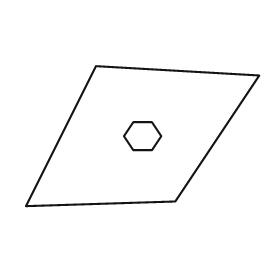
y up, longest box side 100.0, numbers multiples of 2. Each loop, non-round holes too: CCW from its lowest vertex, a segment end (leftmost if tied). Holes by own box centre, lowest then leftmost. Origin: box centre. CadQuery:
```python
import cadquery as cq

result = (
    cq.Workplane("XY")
    .moveTo(-50.0, -30.0)
    .lineTo(14.0, -28.0)
    .lineTo(50.0, 26.0)
    .lineTo(-20.0, 30.0)
    .close()
    .moveTo(-4.0, -6.0)
    .lineTo(4.0, -6.0)
    .lineTo(8.0, 0.0)
    .lineTo(4.0, 6.0)
    .lineTo(-4.0, 6.0)
    .lineTo(-8.0, 0.0)
    .close()
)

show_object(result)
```